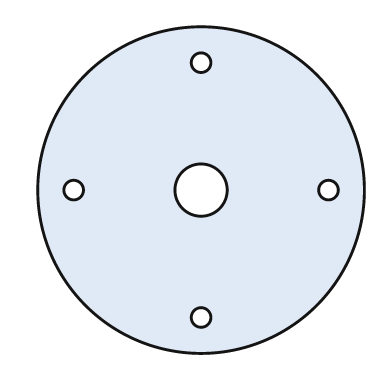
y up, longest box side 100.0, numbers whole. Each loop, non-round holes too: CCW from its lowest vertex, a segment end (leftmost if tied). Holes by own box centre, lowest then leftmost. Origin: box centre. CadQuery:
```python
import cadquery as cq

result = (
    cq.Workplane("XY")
    .moveTo(0.0, 0.0)
    .circle(50.0)
    .moveTo(0.0, -39.0)
    .circle(3.0)
    .moveTo(-39.0, 0.0)
    .circle(3.0)
    .moveTo(0.0, 0.0)
    .circle(8.0)
    .moveTo(39.0, 0.0)
    .circle(3.0)
    .moveTo(0.0, 39.0)
    .circle(3.0)
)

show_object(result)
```